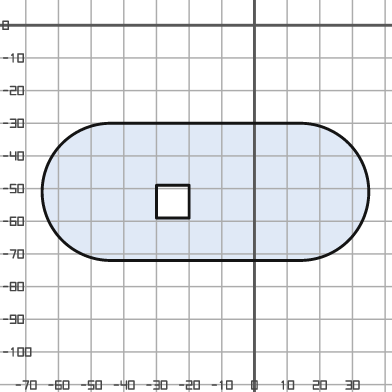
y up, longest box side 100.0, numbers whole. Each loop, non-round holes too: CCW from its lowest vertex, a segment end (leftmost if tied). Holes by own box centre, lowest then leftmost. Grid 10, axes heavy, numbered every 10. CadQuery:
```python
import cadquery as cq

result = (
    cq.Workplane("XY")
    .moveTo(-44.0, -72.0)
    .lineTo(14.0, -72.0)
    .threePointArc((35.0, -51.0), (14.0, -30.0))
    .lineTo(-44.0, -30.0)
    .threePointArc((-65.0, -51.0), (-44.0, -72.0))
    .close()
    .moveTo(-30.0, -59.0)
    .lineTo(-20.0, -59.0)
    .lineTo(-20.0, -49.0)
    .lineTo(-30.0, -49.0)
    .close()
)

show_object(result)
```